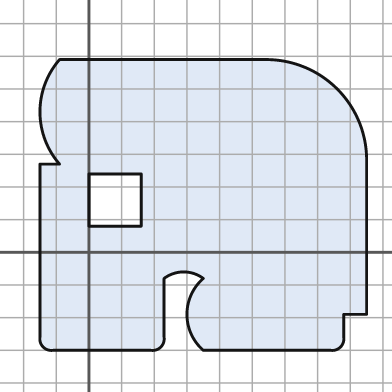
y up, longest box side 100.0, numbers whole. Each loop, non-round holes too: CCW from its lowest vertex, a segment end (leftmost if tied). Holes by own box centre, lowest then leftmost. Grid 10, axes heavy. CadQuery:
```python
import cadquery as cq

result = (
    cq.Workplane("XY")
    .moveTo(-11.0, -30.0)
    .lineTo(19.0, -30.0)
    .threePointArc((22.0, -29.0), (23.0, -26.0))
    .lineTo(23.0, -8.0)
    .threePointArc((29.0, -6.0), (35.0, -8.0))
    .threePointArc((30.0, -19.0), (35.0, -30.0))
    .lineTo(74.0, -30.0)
    .threePointArc((77.0, -29.0), (78.0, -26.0))
    .lineTo(78.0, -19.0)
    .lineTo(85.0, -19.0)
    .lineTo(85.0, 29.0)
    .threePointArc((76.0, 50.0), (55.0, 59.0))
    .lineTo(-9.0, 59.0)
    .threePointArc((-15.0, 43.0), (-9.0, 27.0))
    .lineTo(-15.0, 27.0)
    .lineTo(-15.0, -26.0)
    .threePointArc((-14.0, -29.0), (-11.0, -30.0))
    .close()
    .moveTo(0.0, 8.0)
    .lineTo(16.0, 8.0)
    .lineTo(16.0, 24.0)
    .lineTo(0.0, 24.0)
    .close()
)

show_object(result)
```